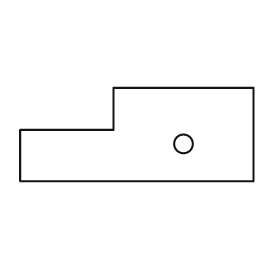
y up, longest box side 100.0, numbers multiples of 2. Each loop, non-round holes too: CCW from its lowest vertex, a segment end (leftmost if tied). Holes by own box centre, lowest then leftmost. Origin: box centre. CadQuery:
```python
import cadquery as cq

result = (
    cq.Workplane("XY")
    .moveTo(-50.0, -20.0)
    .lineTo(50.0, -20.0)
    .lineTo(50.0, 20.0)
    .lineTo(-10.0, 20.0)
    .lineTo(-10.0, 2.0)
    .lineTo(-50.0, 2.0)
    .close()
    .moveTo(20.0, -4.0)
    .circle(4.0)
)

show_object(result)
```